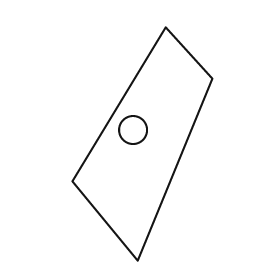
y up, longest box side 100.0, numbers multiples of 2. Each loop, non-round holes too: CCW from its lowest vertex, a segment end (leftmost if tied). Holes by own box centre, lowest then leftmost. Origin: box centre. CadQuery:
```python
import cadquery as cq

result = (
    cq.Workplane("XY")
    .moveTo(-2.0, -50.0)
    .lineTo(30.0, 28.0)
    .lineTo(10.0, 50.0)
    .lineTo(-30.0, -16.0)
    .close()
    .moveTo(-4.0, 6.0)
    .circle(6.0)
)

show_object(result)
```